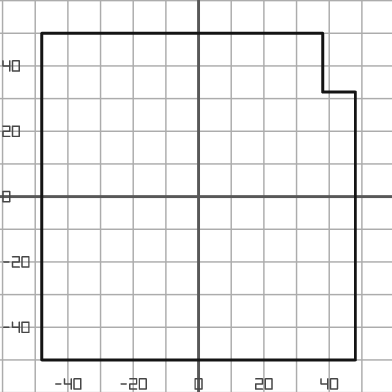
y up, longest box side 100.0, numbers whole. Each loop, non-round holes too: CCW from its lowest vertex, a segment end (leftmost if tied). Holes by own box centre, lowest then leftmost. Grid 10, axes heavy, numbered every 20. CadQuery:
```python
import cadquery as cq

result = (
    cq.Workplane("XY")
    .moveTo(-48.0, -50.0)
    .lineTo(48.0, -50.0)
    .lineTo(48.0, 32.0)
    .lineTo(38.0, 32.0)
    .lineTo(38.0, 50.0)
    .lineTo(-48.0, 50.0)
    .close()
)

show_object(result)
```